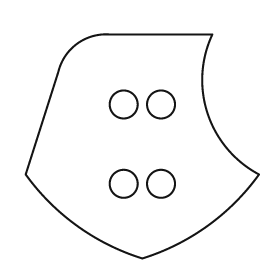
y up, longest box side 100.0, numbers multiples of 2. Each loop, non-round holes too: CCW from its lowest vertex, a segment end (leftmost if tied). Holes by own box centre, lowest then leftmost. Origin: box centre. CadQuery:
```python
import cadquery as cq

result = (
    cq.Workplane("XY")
    .moveTo(0.0, -48.0)
    .threePointArc((28.0, -34.0), (50.0, -12.0))
    .threePointArc((28.0, 14.0), (30.0, 48.0))
    .lineTo(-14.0, 48.0)
    .threePointArc((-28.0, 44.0), (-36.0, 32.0))
    .lineTo(-50.0, -12.0)
    .threePointArc((-28.0, -34.0), (0.0, -48.0))
    .close()
    .moveTo(-8.0, -16.0)
    .circle(6.0)
    .moveTo(8.0, -16.0)
    .circle(6.0)
    .moveTo(-8.0, 18.0)
    .circle(6.0)
    .moveTo(8.0, 18.0)
    .circle(6.0)
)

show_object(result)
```